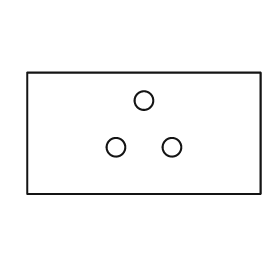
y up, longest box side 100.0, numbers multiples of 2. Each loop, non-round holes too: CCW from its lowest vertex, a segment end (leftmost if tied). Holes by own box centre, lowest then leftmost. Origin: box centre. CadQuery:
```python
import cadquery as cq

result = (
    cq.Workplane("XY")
    .moveTo(-50.0, -26.0)
    .lineTo(50.0, -26.0)
    .lineTo(50.0, 26.0)
    .lineTo(-50.0, 26.0)
    .close()
    .moveTo(-12.0, -6.0)
    .circle(4.0)
    .moveTo(12.0, -6.0)
    .circle(4.0)
    .moveTo(0.0, 14.0)
    .circle(4.0)
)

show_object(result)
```